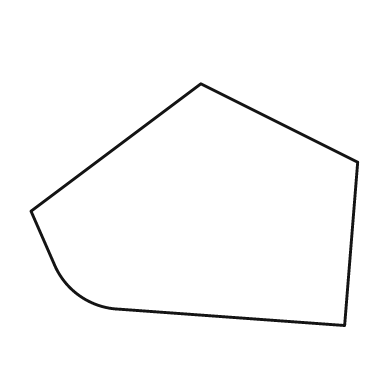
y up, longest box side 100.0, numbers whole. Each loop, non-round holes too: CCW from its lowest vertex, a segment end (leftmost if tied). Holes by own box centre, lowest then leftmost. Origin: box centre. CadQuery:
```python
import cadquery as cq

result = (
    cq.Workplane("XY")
    .moveTo(46.0, -37.0)
    .lineTo(50.0, 13.0)
    .lineTo(2.0, 37.0)
    .lineTo(-50.0, -2.0)
    .lineTo(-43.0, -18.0)
    .threePointArc((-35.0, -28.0), (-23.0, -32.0))
    .close()
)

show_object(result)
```